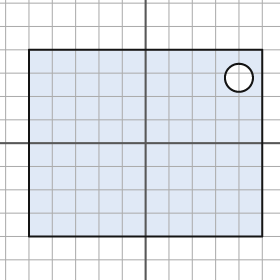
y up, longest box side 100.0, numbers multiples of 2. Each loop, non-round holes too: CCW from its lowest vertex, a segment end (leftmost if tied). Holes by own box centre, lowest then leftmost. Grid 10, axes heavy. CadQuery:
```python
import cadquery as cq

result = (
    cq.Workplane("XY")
    .moveTo(-50.0, -40.0)
    .lineTo(50.0, -40.0)
    .lineTo(50.0, 40.0)
    .lineTo(-50.0, 40.0)
    .close()
    .moveTo(40.0, 28.0)
    .circle(6.0)
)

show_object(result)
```